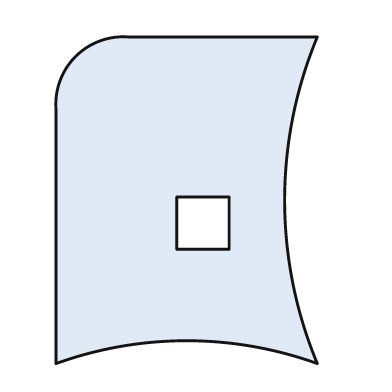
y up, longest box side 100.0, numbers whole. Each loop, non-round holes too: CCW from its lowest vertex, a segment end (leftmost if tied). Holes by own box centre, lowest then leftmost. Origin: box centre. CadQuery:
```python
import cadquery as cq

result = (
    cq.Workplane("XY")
    .moveTo(-40.0, -50.0)
    .threePointArc((0.0, -43.0), (40.0, -50.0))
    .threePointArc((30.0, 0.0), (40.0, 50.0))
    .lineTo(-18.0, 50.0)
    .threePointArc((-34.0, 44.0), (-40.0, 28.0))
    .close()
    .moveTo(-3.0, -15.0)
    .lineTo(13.0, -15.0)
    .lineTo(13.0, 1.0)
    .lineTo(-3.0, 1.0)
    .close()
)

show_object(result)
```